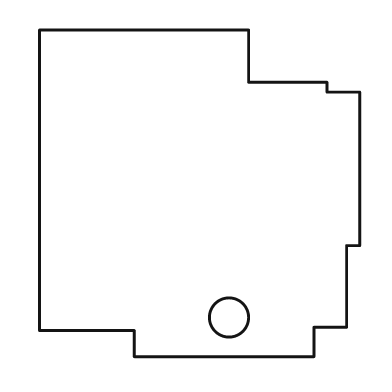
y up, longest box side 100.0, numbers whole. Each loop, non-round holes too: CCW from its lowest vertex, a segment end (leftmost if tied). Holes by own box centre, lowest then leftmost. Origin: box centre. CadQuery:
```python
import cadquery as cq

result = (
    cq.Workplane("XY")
    .moveTo(-20.0, -50.0)
    .lineTo(35.0, -50.0)
    .lineTo(35.0, -41.0)
    .lineTo(45.0, -41.0)
    .lineTo(45.0, -16.0)
    .lineTo(49.0, -16.0)
    .lineTo(49.0, 31.0)
    .lineTo(39.0, 31.0)
    .lineTo(39.0, 34.0)
    .lineTo(15.0, 34.0)
    .lineTo(15.0, 50.0)
    .lineTo(-49.0, 50.0)
    .lineTo(-49.0, -42.0)
    .lineTo(-20.0, -42.0)
    .close()
    .moveTo(9.0, -38.0)
    .circle(6.0)
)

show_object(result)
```